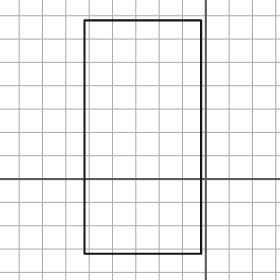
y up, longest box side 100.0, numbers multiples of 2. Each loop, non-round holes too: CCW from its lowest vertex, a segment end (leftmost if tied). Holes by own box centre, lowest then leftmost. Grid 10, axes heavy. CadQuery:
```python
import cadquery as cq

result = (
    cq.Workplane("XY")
    .moveTo(-52.0, -32.0)
    .lineTo(-2.0, -32.0)
    .lineTo(-2.0, 68.0)
    .lineTo(-52.0, 68.0)
    .close()
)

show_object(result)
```